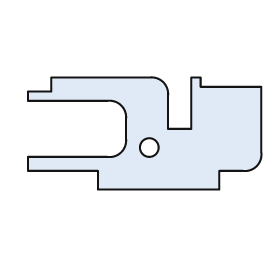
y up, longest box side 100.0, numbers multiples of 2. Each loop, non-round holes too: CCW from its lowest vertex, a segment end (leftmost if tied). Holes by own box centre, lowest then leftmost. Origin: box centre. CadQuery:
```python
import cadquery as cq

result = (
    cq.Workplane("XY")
    .moveTo(-20.0, -24.0)
    .lineTo(32.0, -24.0)
    .lineTo(32.0, -16.0)
    .lineTo(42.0, -16.0)
    .threePointArc((48.0, -14.0), (50.0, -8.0))
    .lineTo(50.0, 20.0)
    .lineTo(24.0, 20.0)
    .lineTo(24.0, 24.0)
    .lineTo(20.0, 24.0)
    .lineTo(20.0, 2.0)
    .lineTo(10.0, 2.0)
    .lineTo(10.0, 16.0)
    .threePointArc((8.0, 22.0), (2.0, 24.0))
    .lineTo(-40.0, 24.0)
    .lineTo(-40.0, 18.0)
    .lineTo(-50.0, 18.0)
    .lineTo(-50.0, 14.0)
    .lineTo(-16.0, 14.0)
    .threePointArc((-10.0, 12.0), (-8.0, 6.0))
    .lineTo(-8.0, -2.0)
    .threePointArc((-10.0, -8.0), (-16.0, -10.0))
    .lineTo(-50.0, -10.0)
    .lineTo(-50.0, -16.0)
    .lineTo(-20.0, -16.0)
    .close()
    .moveTo(2.0, -6.0)
    .circle(4.0)
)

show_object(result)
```